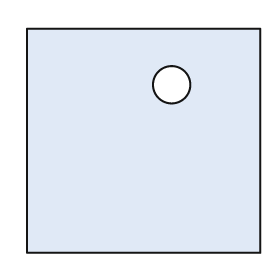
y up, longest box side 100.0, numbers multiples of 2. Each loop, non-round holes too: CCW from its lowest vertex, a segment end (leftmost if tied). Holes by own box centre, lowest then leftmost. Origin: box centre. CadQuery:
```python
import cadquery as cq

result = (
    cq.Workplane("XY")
    .moveTo(-50.0, -48.0)
    .lineTo(50.0, -48.0)
    .lineTo(50.0, 48.0)
    .lineTo(-50.0, 48.0)
    .close()
    .moveTo(12.0, 24.0)
    .circle(8.0)
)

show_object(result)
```